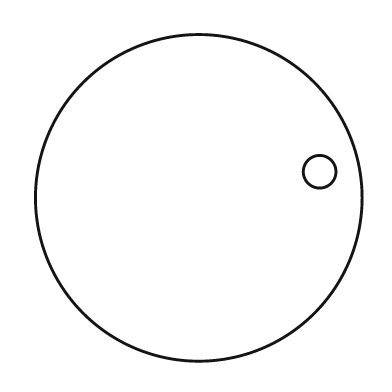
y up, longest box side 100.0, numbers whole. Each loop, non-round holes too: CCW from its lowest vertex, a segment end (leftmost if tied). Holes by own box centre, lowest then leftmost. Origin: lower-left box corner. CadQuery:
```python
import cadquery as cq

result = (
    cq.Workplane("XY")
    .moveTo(50.0, 50.0)
    .circle(50.0)
    .moveTo(87.0, 58.0)
    .circle(5.0)
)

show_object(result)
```